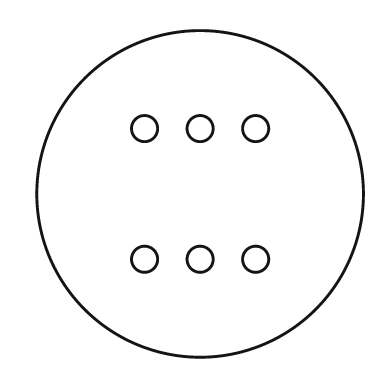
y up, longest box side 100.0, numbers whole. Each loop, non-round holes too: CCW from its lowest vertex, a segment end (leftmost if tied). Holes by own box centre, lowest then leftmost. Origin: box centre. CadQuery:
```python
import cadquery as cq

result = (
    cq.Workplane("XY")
    .moveTo(0.0, 0.0)
    .circle(50.0)
    .moveTo(-17.0, -20.0)
    .circle(4.0)
    .moveTo(0.0, -20.0)
    .circle(4.0)
    .moveTo(17.0, -20.0)
    .circle(4.0)
    .moveTo(-17.0, 20.0)
    .circle(4.0)
    .moveTo(0.0, 20.0)
    .circle(4.0)
    .moveTo(17.0, 20.0)
    .circle(4.0)
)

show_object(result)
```